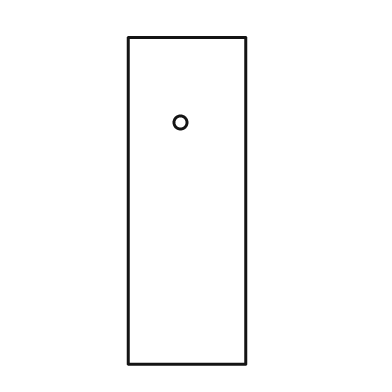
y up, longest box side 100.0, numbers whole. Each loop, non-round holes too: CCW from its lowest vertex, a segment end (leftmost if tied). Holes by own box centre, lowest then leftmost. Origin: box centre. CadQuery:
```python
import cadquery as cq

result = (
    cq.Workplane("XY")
    .moveTo(-18.0, -50.0)
    .lineTo(18.0, -50.0)
    .lineTo(18.0, 50.0)
    .lineTo(-18.0, 50.0)
    .close()
    .moveTo(-2.0, 24.0)
    .circle(2.0)
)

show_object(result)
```